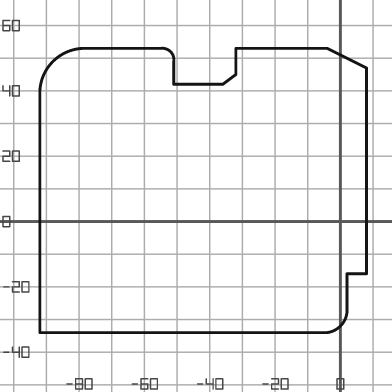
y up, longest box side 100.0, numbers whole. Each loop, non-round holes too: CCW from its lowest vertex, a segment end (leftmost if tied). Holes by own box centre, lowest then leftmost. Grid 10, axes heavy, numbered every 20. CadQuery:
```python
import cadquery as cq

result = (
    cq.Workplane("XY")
    .moveTo(-92.0, -34.0)
    .lineTo(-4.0, -34.0)
    .threePointArc((0.0, -32.0), (2.0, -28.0))
    .lineTo(2.0, -16.0)
    .lineTo(8.0, -16.0)
    .lineTo(8.0, 47.0)
    .lineTo(-4.0, 53.0)
    .lineTo(-32.0, 53.0)
    .lineTo(-32.0, 45.0)
    .lineTo(-36.0, 42.0)
    .lineTo(-51.0, 42.0)
    .lineTo(-51.0, 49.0)
    .threePointArc((-52.0, 52.0), (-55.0, 53.0))
    .lineTo(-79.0, 53.0)
    .threePointArc((-88.0, 49.0), (-92.0, 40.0))
    .close()
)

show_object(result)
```